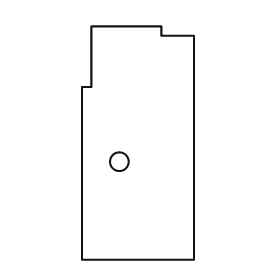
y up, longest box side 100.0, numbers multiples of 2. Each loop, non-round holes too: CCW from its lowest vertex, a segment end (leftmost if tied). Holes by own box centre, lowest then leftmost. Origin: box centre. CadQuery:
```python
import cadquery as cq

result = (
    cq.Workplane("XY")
    .moveTo(-24.0, -50.0)
    .lineTo(24.0, -50.0)
    .lineTo(24.0, 46.0)
    .lineTo(10.0, 46.0)
    .lineTo(10.0, 50.0)
    .lineTo(-20.0, 50.0)
    .lineTo(-20.0, 24.0)
    .lineTo(-24.0, 24.0)
    .close()
    .moveTo(-8.0, -8.0)
    .circle(4.0)
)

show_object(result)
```